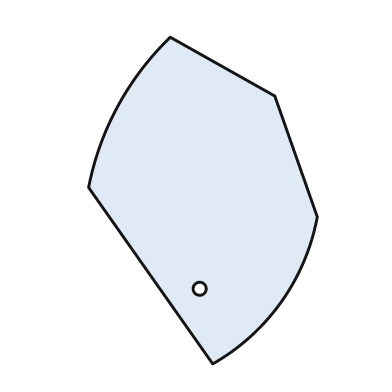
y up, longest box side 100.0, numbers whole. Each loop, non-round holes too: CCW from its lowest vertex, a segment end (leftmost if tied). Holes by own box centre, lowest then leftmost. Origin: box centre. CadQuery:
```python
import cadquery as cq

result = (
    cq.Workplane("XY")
    .moveTo(3.0, -50.0)
    .threePointArc((24.0, -31.0), (35.0, -5.0))
    .lineTo(22.0, 32.0)
    .lineTo(-10.0, 50.0)
    .threePointArc((-26.0, 29.0), (-35.0, 4.0))
    .close()
    .moveTo(-1.0, -27.0)
    .circle(2.0)
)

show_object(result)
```